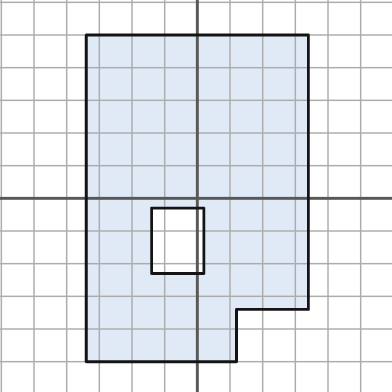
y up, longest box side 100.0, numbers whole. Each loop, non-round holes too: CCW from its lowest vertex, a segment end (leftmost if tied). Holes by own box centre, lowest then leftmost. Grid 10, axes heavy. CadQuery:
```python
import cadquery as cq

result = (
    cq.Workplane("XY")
    .moveTo(-34.0, -50.0)
    .lineTo(12.0, -50.0)
    .lineTo(12.0, -34.0)
    .lineTo(34.0, -34.0)
    .lineTo(34.0, 50.0)
    .lineTo(-34.0, 50.0)
    .close()
    .moveTo(-14.0, -23.0)
    .lineTo(2.0, -23.0)
    .lineTo(2.0, -3.0)
    .lineTo(-14.0, -3.0)
    .close()
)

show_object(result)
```